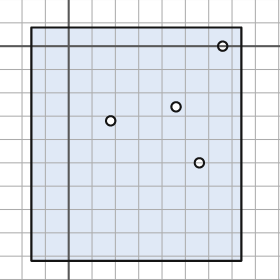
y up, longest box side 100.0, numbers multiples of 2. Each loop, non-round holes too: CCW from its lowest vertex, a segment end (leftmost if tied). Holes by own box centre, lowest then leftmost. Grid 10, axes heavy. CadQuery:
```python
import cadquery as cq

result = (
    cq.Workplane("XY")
    .moveTo(-16.0, -92.0)
    .lineTo(74.0, -92.0)
    .lineTo(74.0, 8.0)
    .lineTo(-16.0, 8.0)
    .close()
    .moveTo(56.0, -50.0)
    .circle(2.0)
    .moveTo(18.0, -32.0)
    .circle(2.0)
    .moveTo(46.0, -26.0)
    .circle(2.0)
    .moveTo(66.0, 0.0)
    .circle(2.0)
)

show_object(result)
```